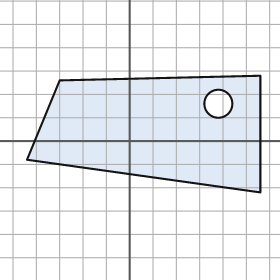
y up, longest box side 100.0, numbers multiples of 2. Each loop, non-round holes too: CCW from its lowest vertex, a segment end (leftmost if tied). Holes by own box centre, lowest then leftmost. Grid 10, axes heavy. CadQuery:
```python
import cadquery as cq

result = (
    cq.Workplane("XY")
    .moveTo(56.0, -22.0)
    .lineTo(56.0, 28.0)
    .lineTo(-30.0, 26.0)
    .lineTo(-44.0, -8.0)
    .close()
    .moveTo(38.0, 16.0)
    .circle(6.0)
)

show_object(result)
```